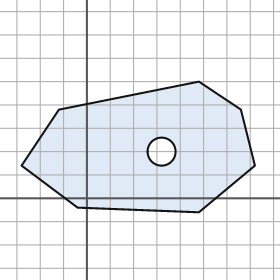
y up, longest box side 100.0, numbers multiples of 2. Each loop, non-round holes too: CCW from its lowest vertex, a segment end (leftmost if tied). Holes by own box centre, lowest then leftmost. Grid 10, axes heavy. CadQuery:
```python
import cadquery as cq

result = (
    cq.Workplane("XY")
    .moveTo(48.0, -6.0)
    .lineTo(72.0, 14.0)
    .lineTo(66.0, 38.0)
    .lineTo(48.0, 50.0)
    .lineTo(-12.0, 38.0)
    .lineTo(-28.0, 14.0)
    .lineTo(-4.0, -4.0)
    .close()
    .moveTo(32.0, 20.0)
    .circle(6.0)
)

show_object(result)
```